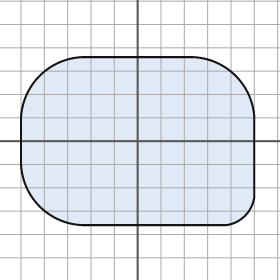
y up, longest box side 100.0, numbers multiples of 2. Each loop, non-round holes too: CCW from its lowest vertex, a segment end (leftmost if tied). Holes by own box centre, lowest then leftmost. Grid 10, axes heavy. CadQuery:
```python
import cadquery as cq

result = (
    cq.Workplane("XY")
    .moveTo(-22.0, -36.0)
    .lineTo(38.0, -36.0)
    .threePointArc((46.0, -32.0), (50.0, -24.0))
    .lineTo(50.0, 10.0)
    .threePointArc((42.0, 28.0), (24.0, 36.0))
    .lineTo(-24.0, 36.0)
    .threePointArc((-42.0, 28.0), (-50.0, 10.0))
    .lineTo(-50.0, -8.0)
    .threePointArc((-42.0, -28.0), (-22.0, -36.0))
    .close()
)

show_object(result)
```